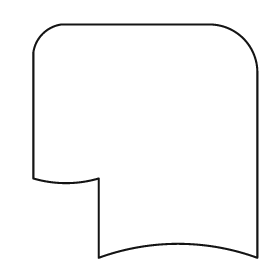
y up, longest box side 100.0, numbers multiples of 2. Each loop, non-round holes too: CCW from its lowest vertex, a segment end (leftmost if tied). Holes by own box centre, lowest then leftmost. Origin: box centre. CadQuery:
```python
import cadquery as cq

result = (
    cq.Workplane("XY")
    .moveTo(-20.0, -50.0)
    .threePointArc((14.0, -44.0), (48.0, -50.0))
    .lineTo(48.0, 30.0)
    .threePointArc((42.0, 44.0), (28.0, 50.0))
    .lineTo(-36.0, 50.0)
    .threePointArc((-44.0, 46.0), (-48.0, 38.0))
    .lineTo(-48.0, -16.0)
    .threePointArc((-34.0, -18.0), (-20.0, -16.0))
    .close()
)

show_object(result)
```